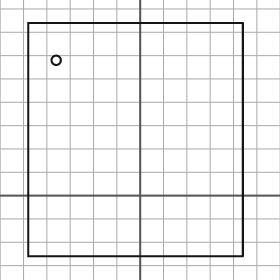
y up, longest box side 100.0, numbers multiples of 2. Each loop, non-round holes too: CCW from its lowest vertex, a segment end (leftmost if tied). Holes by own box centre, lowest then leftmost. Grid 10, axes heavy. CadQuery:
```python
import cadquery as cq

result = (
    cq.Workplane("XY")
    .moveTo(-48.0, -26.0)
    .lineTo(44.0, -26.0)
    .lineTo(44.0, 74.0)
    .lineTo(-48.0, 74.0)
    .close()
    .moveTo(-36.0, 58.0)
    .circle(2.0)
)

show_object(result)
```